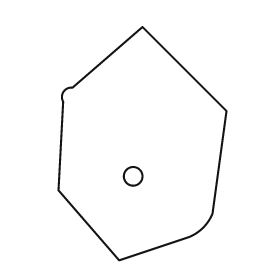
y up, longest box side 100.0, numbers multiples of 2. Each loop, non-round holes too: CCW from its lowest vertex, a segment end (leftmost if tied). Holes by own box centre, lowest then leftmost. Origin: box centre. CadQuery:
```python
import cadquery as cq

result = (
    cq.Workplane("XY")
    .moveTo(-10.0, -50.0)
    .lineTo(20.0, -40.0)
    .threePointArc((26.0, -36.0), (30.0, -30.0))
    .lineTo(36.0, 14.0)
    .lineTo(0.0, 50.0)
    .lineTo(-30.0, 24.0)
    .threePointArc((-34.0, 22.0), (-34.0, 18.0))
    .lineTo(-36.0, -20.0)
    .close()
    .moveTo(-4.0, -14.0)
    .circle(4.0)
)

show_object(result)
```